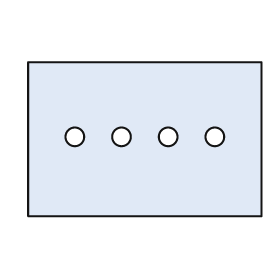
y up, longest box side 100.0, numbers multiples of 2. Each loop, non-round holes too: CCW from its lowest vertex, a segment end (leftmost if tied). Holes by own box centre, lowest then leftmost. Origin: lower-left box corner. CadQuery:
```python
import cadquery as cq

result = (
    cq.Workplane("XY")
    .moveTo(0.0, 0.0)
    .lineTo(100.0, 0.0)
    .lineTo(100.0, 66.0)
    .lineTo(0.0, 66.0)
    .close()
    .moveTo(20.0, 34.0)
    .circle(4.0)
    .moveTo(40.0, 34.0)
    .circle(4.0)
    .moveTo(60.0, 34.0)
    .circle(4.0)
    .moveTo(80.0, 34.0)
    .circle(4.0)
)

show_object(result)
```